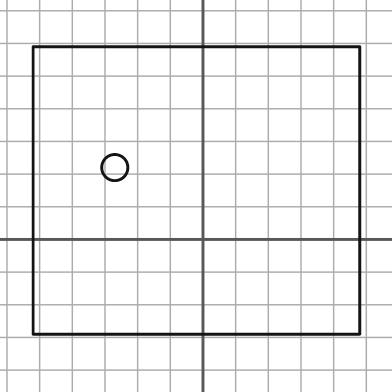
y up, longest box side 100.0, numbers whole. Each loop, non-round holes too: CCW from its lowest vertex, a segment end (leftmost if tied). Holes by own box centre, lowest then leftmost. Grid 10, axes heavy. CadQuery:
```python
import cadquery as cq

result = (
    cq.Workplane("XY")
    .moveTo(-52.0, -29.0)
    .lineTo(48.0, -29.0)
    .lineTo(48.0, 59.0)
    .lineTo(-52.0, 59.0)
    .close()
    .moveTo(-27.0, 22.0)
    .circle(4.0)
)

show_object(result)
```